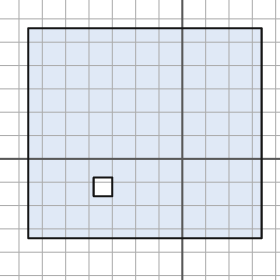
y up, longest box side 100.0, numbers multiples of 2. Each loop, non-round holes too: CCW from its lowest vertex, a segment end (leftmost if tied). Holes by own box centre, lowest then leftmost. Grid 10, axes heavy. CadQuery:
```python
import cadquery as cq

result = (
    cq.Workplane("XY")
    .moveTo(-66.0, -34.0)
    .lineTo(34.0, -34.0)
    .lineTo(34.0, 56.0)
    .lineTo(-66.0, 56.0)
    .close()
    .moveTo(-38.0, -16.0)
    .lineTo(-30.0, -16.0)
    .lineTo(-30.0, -8.0)
    .lineTo(-38.0, -8.0)
    .close()
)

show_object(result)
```